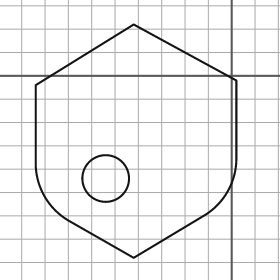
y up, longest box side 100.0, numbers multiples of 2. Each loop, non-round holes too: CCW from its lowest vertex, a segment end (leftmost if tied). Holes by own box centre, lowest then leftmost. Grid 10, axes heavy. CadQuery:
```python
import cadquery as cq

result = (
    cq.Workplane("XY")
    .moveTo(-42.0, -78.0)
    .lineTo(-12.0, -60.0)
    .threePointArc((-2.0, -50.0), (2.0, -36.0))
    .lineTo(2.0, -2.0)
    .lineTo(-42.0, 22.0)
    .lineTo(-84.0, -4.0)
    .lineTo(-84.0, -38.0)
    .threePointArc((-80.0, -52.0), (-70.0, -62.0))
    .close()
    .moveTo(-54.0, -44.0)
    .circle(10.0)
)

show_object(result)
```